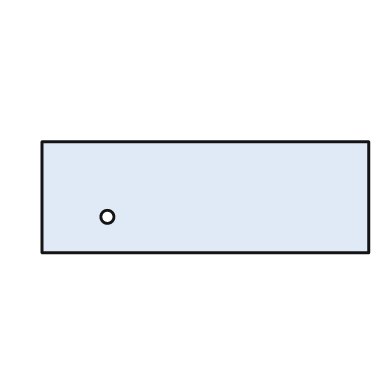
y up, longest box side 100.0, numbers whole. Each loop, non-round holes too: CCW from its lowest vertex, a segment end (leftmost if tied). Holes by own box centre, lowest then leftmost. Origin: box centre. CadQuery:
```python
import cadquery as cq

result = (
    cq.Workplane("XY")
    .moveTo(-50.0, -17.0)
    .lineTo(50.0, -17.0)
    .lineTo(50.0, 17.0)
    .lineTo(-50.0, 17.0)
    .close()
    .moveTo(-30.0, -6.0)
    .circle(2.0)
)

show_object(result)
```